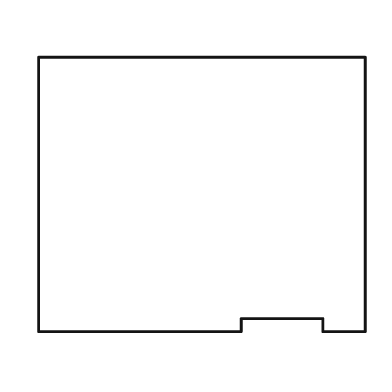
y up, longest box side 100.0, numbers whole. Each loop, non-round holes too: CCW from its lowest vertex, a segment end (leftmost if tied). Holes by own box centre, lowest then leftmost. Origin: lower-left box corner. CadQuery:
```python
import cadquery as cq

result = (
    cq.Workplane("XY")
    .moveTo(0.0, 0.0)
    .lineTo(62.0, 0.0)
    .lineTo(62.0, 4.0)
    .lineTo(87.0, 4.0)
    .lineTo(87.0, 0.0)
    .lineTo(100.0, 0.0)
    .lineTo(100.0, 84.0)
    .lineTo(0.0, 84.0)
    .close()
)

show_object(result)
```